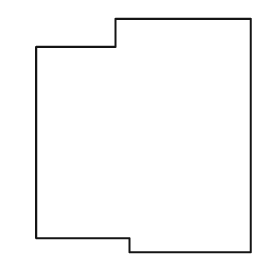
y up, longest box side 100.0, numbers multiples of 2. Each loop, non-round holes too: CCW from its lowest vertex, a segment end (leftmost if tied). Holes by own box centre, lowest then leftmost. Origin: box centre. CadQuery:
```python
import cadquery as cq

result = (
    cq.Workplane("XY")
    .moveTo(-6.0, -50.0)
    .lineTo(46.0, -50.0)
    .lineTo(46.0, 50.0)
    .lineTo(-12.0, 50.0)
    .lineTo(-12.0, 38.0)
    .lineTo(-46.0, 38.0)
    .lineTo(-46.0, -44.0)
    .lineTo(-6.0, -44.0)
    .close()
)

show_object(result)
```